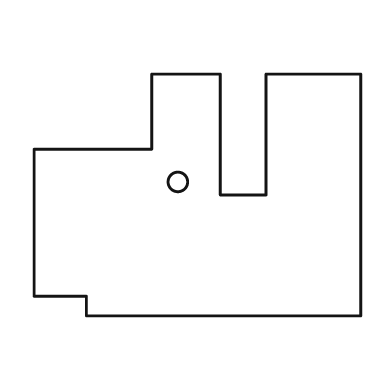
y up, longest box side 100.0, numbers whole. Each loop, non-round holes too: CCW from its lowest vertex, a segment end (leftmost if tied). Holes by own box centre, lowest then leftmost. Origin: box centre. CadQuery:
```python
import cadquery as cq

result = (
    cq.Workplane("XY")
    .moveTo(-34.0, -37.0)
    .lineTo(50.0, -37.0)
    .lineTo(50.0, 37.0)
    .lineTo(21.0, 37.0)
    .lineTo(21.0, 0.0)
    .lineTo(7.0, 0.0)
    .lineTo(7.0, 37.0)
    .lineTo(-14.0, 37.0)
    .lineTo(-14.0, 14.0)
    .lineTo(-50.0, 14.0)
    .lineTo(-50.0, -31.0)
    .lineTo(-34.0, -31.0)
    .close()
    .moveTo(-6.0, 4.0)
    .circle(3.0)
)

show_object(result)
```